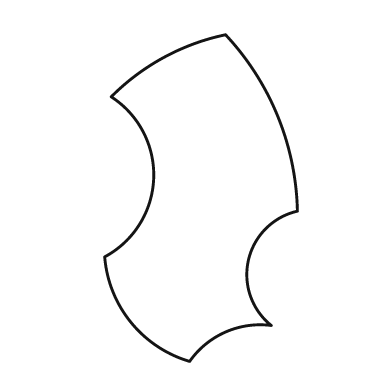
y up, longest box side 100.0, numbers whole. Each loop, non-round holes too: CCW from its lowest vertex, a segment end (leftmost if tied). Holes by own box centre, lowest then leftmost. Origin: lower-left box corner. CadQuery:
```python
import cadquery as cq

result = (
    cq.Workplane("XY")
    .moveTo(26.0, 0.0)
    .threePointArc((37.0, 9.0), (51.0, 11.0))
    .threePointArc((44.0, 31.0), (59.0, 46.0))
    .threePointArc((53.0, 75.0), (37.0, 100.0))
    .threePointArc((18.0, 93.0), (2.0, 81.0))
    .threePointArc((15.0, 56.0), (0.0, 32.0))
    .threePointArc((8.0, 12.0), (26.0, 0.0))
    .close()
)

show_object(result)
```